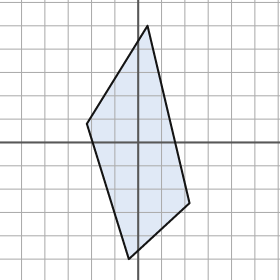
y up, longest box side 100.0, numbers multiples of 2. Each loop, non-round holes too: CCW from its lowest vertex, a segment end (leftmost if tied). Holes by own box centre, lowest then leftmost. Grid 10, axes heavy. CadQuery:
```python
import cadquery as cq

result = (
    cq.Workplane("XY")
    .moveTo(-4.0, -50.0)
    .lineTo(22.0, -26.0)
    .lineTo(4.0, 50.0)
    .lineTo(-22.0, 8.0)
    .close()
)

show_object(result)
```